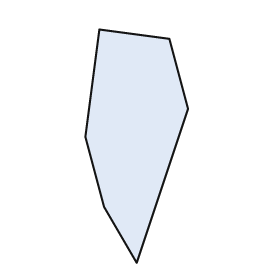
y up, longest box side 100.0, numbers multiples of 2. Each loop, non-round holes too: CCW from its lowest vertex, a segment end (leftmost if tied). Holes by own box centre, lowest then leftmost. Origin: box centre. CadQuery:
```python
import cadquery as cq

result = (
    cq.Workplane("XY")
    .moveTo(0.0, -50.0)
    .lineTo(22.0, 16.0)
    .lineTo(14.0, 46.0)
    .lineTo(-16.0, 50.0)
    .lineTo(-22.0, 4.0)
    .lineTo(-14.0, -26.0)
    .close()
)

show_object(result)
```